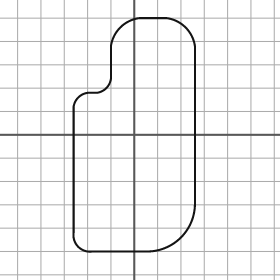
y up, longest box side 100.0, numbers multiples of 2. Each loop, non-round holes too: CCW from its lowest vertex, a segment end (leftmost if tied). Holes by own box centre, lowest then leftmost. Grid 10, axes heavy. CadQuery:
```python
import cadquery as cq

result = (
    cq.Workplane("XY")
    .moveTo(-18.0, -50.0)
    .lineTo(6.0, -50.0)
    .threePointArc((20.0, -44.0), (26.0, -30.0))
    .lineTo(26.0, 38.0)
    .threePointArc((22.0, 46.0), (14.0, 50.0))
    .lineTo(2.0, 50.0)
    .threePointArc((-6.0, 46.0), (-10.0, 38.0))
    .lineTo(-10.0, 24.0)
    .threePointArc((-12.0, 20.0), (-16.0, 18.0))
    .lineTo(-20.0, 18.0)
    .threePointArc((-24.0, 16.0), (-26.0, 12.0))
    .lineTo(-26.0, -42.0)
    .threePointArc((-24.0, -48.0), (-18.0, -50.0))
    .close()
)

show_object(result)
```